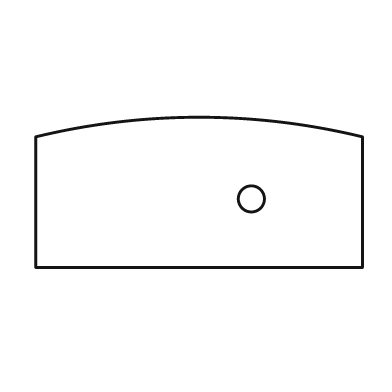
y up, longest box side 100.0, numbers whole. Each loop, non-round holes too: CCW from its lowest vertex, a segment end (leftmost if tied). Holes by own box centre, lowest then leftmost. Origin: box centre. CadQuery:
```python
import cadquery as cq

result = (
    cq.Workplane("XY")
    .moveTo(-50.0, -23.0)
    .lineTo(50.0, -23.0)
    .lineTo(50.0, 17.0)
    .threePointArc((0.0, 23.0), (-50.0, 17.0))
    .close()
    .moveTo(16.0, -2.0)
    .circle(4.0)
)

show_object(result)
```